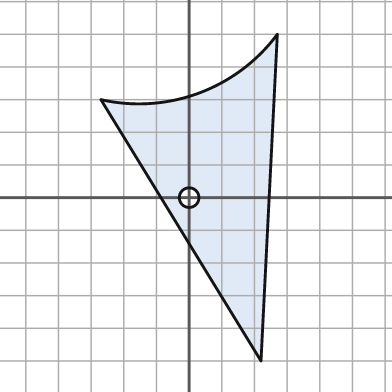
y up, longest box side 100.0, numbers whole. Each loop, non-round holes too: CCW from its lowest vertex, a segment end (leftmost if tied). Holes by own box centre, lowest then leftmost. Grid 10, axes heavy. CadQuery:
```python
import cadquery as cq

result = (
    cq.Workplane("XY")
    .moveTo(22.0, -50.0)
    .lineTo(27.0, 50.0)
    .threePointArc((3.0, 32.0), (-27.0, 30.0))
    .close()
    .moveTo(0.0, 0.0)
    .circle(3.0)
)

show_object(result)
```